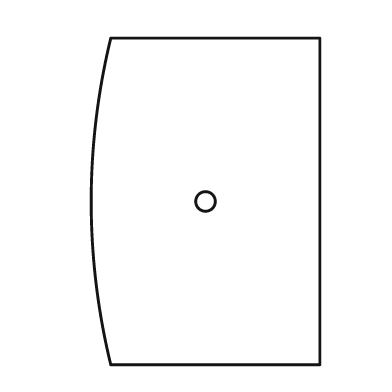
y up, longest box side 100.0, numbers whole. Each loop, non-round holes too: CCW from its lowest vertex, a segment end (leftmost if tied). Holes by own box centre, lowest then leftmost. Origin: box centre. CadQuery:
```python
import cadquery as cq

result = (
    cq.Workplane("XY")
    .moveTo(-29.0, -50.0)
    .lineTo(35.0, -50.0)
    .lineTo(35.0, 50.0)
    .lineTo(-29.0, 50.0)
    .threePointArc((-35.0, 0.0), (-29.0, -50.0))
    .close()
    .moveTo(0.0, 0.0)
    .circle(3.0)
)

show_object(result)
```